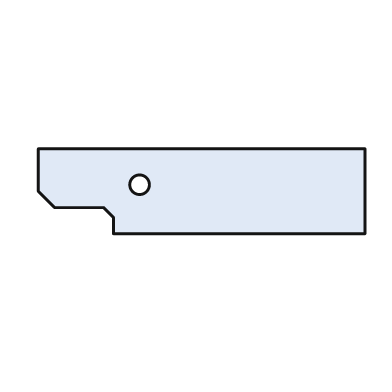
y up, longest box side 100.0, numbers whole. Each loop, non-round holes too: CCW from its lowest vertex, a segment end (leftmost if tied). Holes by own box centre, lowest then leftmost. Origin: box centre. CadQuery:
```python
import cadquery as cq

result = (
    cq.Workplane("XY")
    .moveTo(-27.0, -13.0)
    .lineTo(50.0, -13.0)
    .lineTo(50.0, 13.0)
    .lineTo(-50.0, 13.0)
    .lineTo(-50.0, 0.0)
    .lineTo(-45.0, -5.0)
    .lineTo(-30.0, -5.0)
    .lineTo(-27.0, -8.0)
    .close()
    .moveTo(-19.0, 2.0)
    .circle(3.0)
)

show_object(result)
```